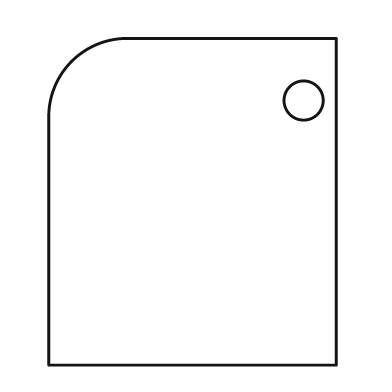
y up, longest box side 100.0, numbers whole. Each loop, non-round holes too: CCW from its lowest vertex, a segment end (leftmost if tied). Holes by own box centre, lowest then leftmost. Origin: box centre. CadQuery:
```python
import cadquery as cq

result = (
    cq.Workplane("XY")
    .moveTo(-44.0, -50.0)
    .lineTo(44.0, -50.0)
    .lineTo(44.0, 50.0)
    .lineTo(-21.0, 50.0)
    .threePointArc((-37.0, 43.0), (-44.0, 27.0))
    .close()
    .moveTo(34.0, 31.0)
    .circle(6.0)
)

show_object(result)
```